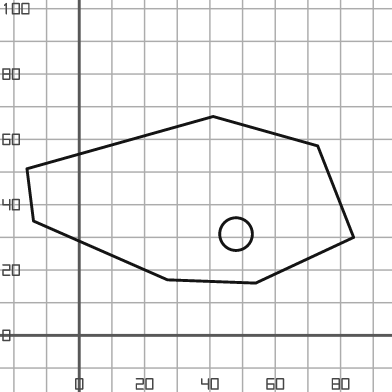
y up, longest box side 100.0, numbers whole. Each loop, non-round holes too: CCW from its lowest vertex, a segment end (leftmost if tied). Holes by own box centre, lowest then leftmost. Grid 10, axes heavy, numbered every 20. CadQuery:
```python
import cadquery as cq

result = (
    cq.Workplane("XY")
    .moveTo(54.0, 16.0)
    .lineTo(84.0, 30.0)
    .lineTo(73.0, 58.0)
    .lineTo(41.0, 67.0)
    .lineTo(-16.0, 51.0)
    .lineTo(-14.0, 35.0)
    .lineTo(27.0, 17.0)
    .close()
    .moveTo(48.0, 31.0)
    .circle(5.0)
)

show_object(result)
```